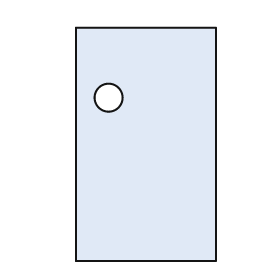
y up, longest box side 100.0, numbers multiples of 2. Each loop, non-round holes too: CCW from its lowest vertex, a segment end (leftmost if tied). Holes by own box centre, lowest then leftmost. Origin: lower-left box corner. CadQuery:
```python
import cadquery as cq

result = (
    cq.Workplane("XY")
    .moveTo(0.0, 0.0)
    .lineTo(60.0, 0.0)
    .lineTo(60.0, 100.0)
    .lineTo(0.0, 100.0)
    .close()
    .moveTo(14.0, 70.0)
    .circle(6.0)
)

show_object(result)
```